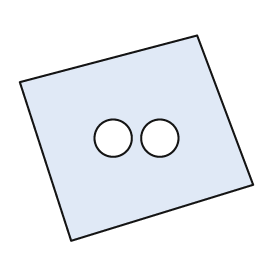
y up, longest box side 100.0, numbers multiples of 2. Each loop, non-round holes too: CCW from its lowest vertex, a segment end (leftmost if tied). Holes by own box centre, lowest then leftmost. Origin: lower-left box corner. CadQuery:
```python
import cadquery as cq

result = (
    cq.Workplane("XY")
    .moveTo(22.0, 0.0)
    .lineTo(100.0, 24.0)
    .lineTo(76.0, 88.0)
    .lineTo(0.0, 68.0)
    .close()
    .moveTo(40.0, 44.0)
    .circle(8.0)
    .moveTo(60.0, 44.0)
    .circle(8.0)
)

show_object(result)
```